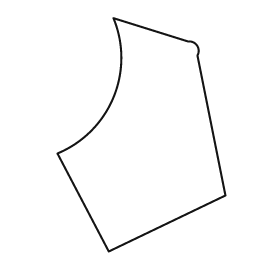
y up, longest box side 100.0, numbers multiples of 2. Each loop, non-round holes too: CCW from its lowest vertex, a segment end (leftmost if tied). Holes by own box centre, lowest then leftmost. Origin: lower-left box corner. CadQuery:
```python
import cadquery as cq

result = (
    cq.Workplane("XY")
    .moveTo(22.0, 0.0)
    .lineTo(72.0, 24.0)
    .lineTo(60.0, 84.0)
    .threePointArc((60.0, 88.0), (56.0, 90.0))
    .lineTo(24.0, 100.0)
    .threePointArc((24.0, 66.0), (0.0, 42.0))
    .close()
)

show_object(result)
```